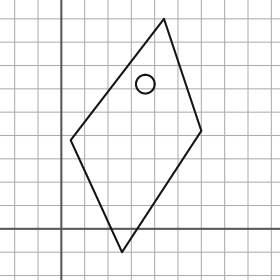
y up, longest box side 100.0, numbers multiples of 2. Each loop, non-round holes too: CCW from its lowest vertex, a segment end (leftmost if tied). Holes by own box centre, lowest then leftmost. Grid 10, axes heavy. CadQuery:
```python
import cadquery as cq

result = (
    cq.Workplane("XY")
    .moveTo(26.0, -10.0)
    .lineTo(60.0, 42.0)
    .lineTo(44.0, 90.0)
    .lineTo(4.0, 38.0)
    .close()
    .moveTo(36.0, 62.0)
    .circle(4.0)
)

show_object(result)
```